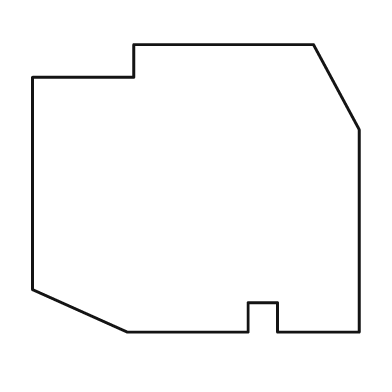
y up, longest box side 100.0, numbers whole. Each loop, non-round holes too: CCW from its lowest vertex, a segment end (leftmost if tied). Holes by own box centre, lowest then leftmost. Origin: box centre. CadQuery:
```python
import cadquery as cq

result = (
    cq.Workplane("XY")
    .moveTo(-21.0, -44.0)
    .lineTo(16.0, -44.0)
    .lineTo(16.0, -35.0)
    .lineTo(25.0, -35.0)
    .lineTo(25.0, -44.0)
    .lineTo(50.0, -44.0)
    .lineTo(50.0, 18.0)
    .lineTo(36.0, 44.0)
    .lineTo(-19.0, 44.0)
    .lineTo(-19.0, 34.0)
    .lineTo(-50.0, 34.0)
    .lineTo(-50.0, -31.0)
    .close()
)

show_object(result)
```